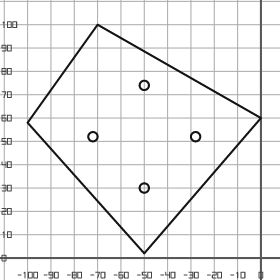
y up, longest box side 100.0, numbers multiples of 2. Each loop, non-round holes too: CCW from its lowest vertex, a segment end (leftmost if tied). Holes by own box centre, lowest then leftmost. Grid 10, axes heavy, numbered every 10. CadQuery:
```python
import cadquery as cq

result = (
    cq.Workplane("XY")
    .moveTo(-50.0, 2.0)
    .lineTo(0.0, 60.0)
    .lineTo(-70.0, 100.0)
    .lineTo(-100.0, 58.0)
    .close()
    .moveTo(-50.0, 30.0)
    .circle(2.0)
    .moveTo(-72.0, 52.0)
    .circle(2.0)
    .moveTo(-28.0, 52.0)
    .circle(2.0)
    .moveTo(-50.0, 74.0)
    .circle(2.0)
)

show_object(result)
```